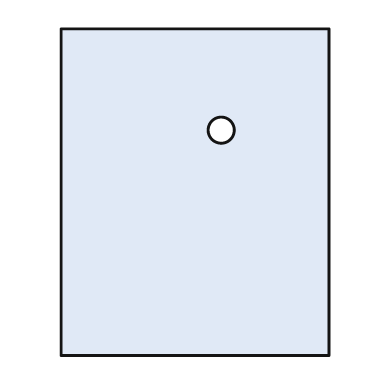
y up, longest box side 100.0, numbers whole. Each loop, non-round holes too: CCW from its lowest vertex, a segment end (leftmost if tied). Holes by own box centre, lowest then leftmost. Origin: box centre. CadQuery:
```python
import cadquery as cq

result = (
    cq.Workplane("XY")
    .moveTo(-41.0, -50.0)
    .lineTo(41.0, -50.0)
    .lineTo(41.0, 50.0)
    .lineTo(-41.0, 50.0)
    .close()
    .moveTo(8.0, 19.0)
    .circle(4.0)
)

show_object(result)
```